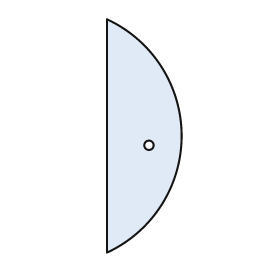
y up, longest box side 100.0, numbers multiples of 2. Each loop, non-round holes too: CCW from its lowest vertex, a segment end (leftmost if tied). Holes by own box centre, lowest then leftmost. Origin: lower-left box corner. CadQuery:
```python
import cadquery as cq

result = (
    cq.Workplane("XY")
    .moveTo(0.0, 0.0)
    .threePointArc((32.0, 50.0), (0.0, 100.0))
    .close()
    .moveTo(18.0, 46.0)
    .circle(2.0)
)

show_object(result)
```